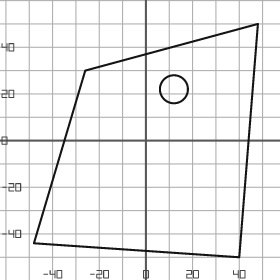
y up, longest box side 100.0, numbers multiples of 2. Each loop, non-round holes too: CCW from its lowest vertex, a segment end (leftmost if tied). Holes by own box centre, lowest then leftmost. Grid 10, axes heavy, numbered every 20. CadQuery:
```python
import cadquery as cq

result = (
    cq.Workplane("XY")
    .moveTo(40.0, -50.0)
    .lineTo(48.0, 50.0)
    .lineTo(-26.0, 30.0)
    .lineTo(-48.0, -44.0)
    .close()
    .moveTo(12.0, 22.0)
    .circle(6.0)
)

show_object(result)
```